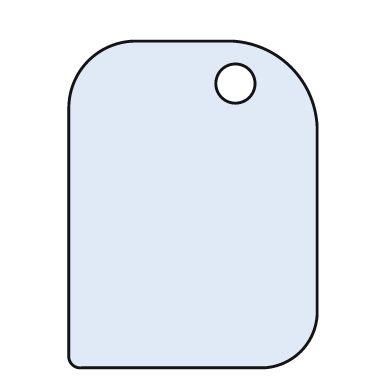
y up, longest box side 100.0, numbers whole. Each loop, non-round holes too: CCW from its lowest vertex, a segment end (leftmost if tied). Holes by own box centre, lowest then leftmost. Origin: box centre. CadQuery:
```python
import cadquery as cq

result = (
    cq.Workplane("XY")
    .moveTo(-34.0, -50.0)
    .lineTo(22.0, -50.0)
    .threePointArc((33.0, -45.0), (38.0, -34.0))
    .lineTo(38.0, 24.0)
    .threePointArc((30.0, 42.0), (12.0, 50.0))
    .lineTo(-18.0, 50.0)
    .threePointArc((-32.0, 44.0), (-38.0, 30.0))
    .lineTo(-38.0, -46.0)
    .threePointArc((-37.0, -49.0), (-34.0, -50.0))
    .close()
    .moveTo(13.0, 37.0)
    .circle(6.0)
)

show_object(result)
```